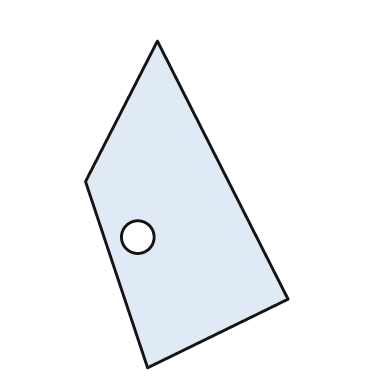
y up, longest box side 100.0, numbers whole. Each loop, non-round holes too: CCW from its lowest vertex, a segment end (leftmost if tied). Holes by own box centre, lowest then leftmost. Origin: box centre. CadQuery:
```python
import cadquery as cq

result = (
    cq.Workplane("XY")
    .moveTo(-12.0, -50.0)
    .lineTo(31.0, -29.0)
    .lineTo(-9.0, 50.0)
    .lineTo(-31.0, 7.0)
    .close()
    .moveTo(-15.0, -10.0)
    .circle(5.0)
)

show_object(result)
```